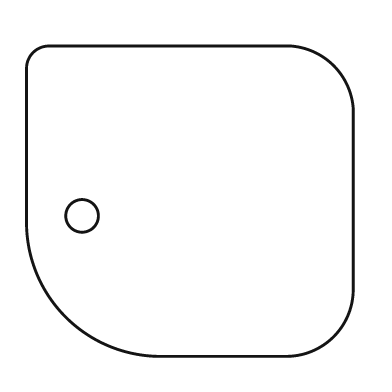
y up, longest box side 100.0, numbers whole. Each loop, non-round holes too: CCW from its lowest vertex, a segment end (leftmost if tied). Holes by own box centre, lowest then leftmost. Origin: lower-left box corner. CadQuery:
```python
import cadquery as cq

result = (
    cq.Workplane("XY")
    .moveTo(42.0, 0.0)
    .lineTo(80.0, 0.0)
    .threePointArc((94.0, 6.0), (100.0, 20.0))
    .lineTo(100.0, 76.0)
    .threePointArc((94.0, 89.0), (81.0, 95.0))
    .lineTo(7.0, 95.0)
    .threePointArc((2.0, 93.0), (0.0, 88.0))
    .lineTo(0.0, 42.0)
    .threePointArc((12.0, 12.0), (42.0, 0.0))
    .close()
    .moveTo(17.0, 43.0)
    .circle(5.0)
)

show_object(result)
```